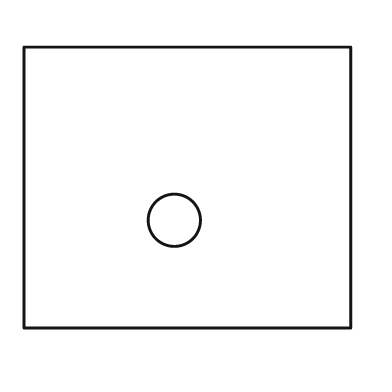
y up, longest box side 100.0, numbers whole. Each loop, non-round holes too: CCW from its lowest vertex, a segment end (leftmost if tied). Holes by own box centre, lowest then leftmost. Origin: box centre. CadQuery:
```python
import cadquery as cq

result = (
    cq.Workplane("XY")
    .moveTo(-50.0, -43.0)
    .lineTo(50.0, -43.0)
    .lineTo(50.0, 43.0)
    .lineTo(-50.0, 43.0)
    .close()
    .moveTo(-4.0, -10.0)
    .circle(8.0)
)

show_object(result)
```